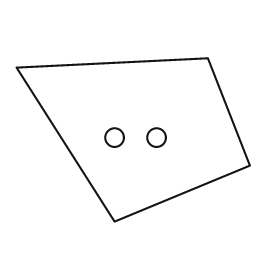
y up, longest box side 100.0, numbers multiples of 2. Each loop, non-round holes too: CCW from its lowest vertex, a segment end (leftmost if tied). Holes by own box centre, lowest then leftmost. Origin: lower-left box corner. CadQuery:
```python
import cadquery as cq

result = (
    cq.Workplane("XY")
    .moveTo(42.0, 0.0)
    .lineTo(100.0, 24.0)
    .lineTo(82.0, 70.0)
    .lineTo(0.0, 66.0)
    .close()
    .moveTo(42.0, 36.0)
    .circle(4.0)
    .moveTo(60.0, 36.0)
    .circle(4.0)
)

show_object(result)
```